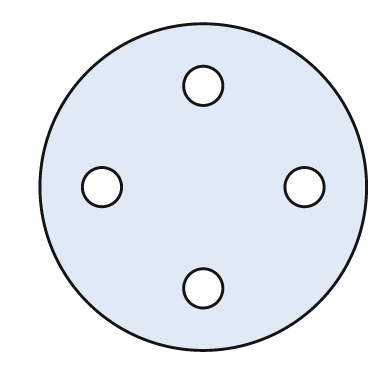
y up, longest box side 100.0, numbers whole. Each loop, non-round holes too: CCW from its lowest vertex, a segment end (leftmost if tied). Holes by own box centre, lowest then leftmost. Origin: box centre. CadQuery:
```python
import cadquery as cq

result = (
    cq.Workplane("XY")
    .moveTo(0.0, 0.0)
    .circle(50.0)
    .moveTo(0.0, -31.0)
    .circle(6.0)
    .moveTo(-31.0, 0.0)
    .circle(6.0)
    .moveTo(31.0, 0.0)
    .circle(6.0)
    .moveTo(0.0, 31.0)
    .circle(6.0)
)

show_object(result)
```